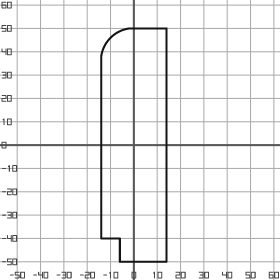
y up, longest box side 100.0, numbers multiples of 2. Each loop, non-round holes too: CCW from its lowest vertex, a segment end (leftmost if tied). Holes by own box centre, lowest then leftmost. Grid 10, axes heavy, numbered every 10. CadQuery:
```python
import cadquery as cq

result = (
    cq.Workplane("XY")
    .moveTo(-6.0, -50.0)
    .lineTo(14.0, -50.0)
    .lineTo(14.0, 50.0)
    .lineTo(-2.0, 50.0)
    .threePointArc((-10.0, 46.0), (-14.0, 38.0))
    .lineTo(-14.0, -40.0)
    .lineTo(-6.0, -40.0)
    .close()
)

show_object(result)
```